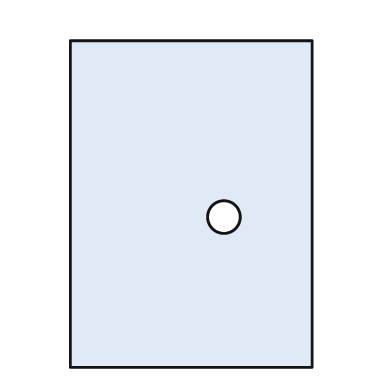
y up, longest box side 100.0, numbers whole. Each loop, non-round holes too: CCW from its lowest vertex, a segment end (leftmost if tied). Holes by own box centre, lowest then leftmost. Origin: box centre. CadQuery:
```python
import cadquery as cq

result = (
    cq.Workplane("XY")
    .moveTo(-37.0, -50.0)
    .lineTo(37.0, -50.0)
    .lineTo(37.0, 50.0)
    .lineTo(-37.0, 50.0)
    .close()
    .moveTo(10.0, -4.0)
    .circle(5.0)
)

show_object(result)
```